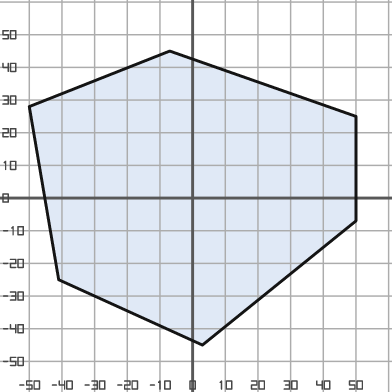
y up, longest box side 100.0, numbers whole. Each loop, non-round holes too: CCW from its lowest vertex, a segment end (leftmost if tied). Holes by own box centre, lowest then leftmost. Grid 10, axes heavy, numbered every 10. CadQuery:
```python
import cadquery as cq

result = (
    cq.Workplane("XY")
    .moveTo(3.0, -45.0)
    .lineTo(50.0, -7.0)
    .lineTo(50.0, 25.0)
    .lineTo(-7.0, 45.0)
    .lineTo(-50.0, 28.0)
    .lineTo(-41.0, -25.0)
    .close()
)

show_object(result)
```